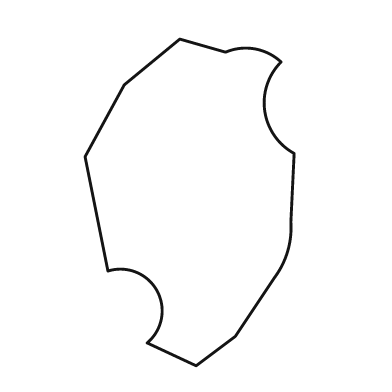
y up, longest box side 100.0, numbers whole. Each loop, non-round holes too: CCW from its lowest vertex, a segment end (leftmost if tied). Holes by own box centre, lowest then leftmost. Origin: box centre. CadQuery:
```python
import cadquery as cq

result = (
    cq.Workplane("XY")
    .moveTo(2.0, -50.0)
    .lineTo(14.0, -41.0)
    .lineTo(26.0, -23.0)
    .threePointArc((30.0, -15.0), (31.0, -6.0))
    .lineTo(32.0, 15.0)
    .threePointArc((23.0, 28.0), (28.0, 43.0))
    .threePointArc((20.0, 47.0), (11.0, 46.0))
    .lineTo(-3.0, 50.0)
    .lineTo(-20.0, 36.0)
    .lineTo(-32.0, 14.0)
    .lineTo(-25.0, -21.0)
    .threePointArc((-10.0, -27.0), (-13.0, -43.0))
    .close()
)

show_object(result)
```